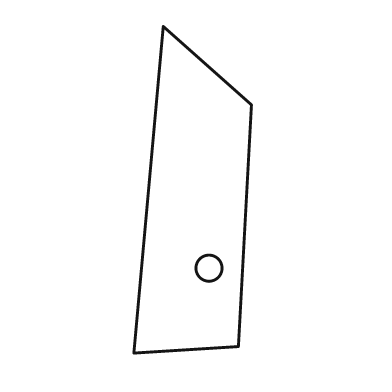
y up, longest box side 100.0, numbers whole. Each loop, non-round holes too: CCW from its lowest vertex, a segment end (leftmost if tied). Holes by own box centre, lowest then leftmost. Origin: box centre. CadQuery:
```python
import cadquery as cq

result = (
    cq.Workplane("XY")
    .moveTo(-18.0, -50.0)
    .lineTo(14.0, -48.0)
    .lineTo(18.0, 26.0)
    .lineTo(-9.0, 50.0)
    .close()
    .moveTo(5.0, -24.0)
    .circle(4.0)
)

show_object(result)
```